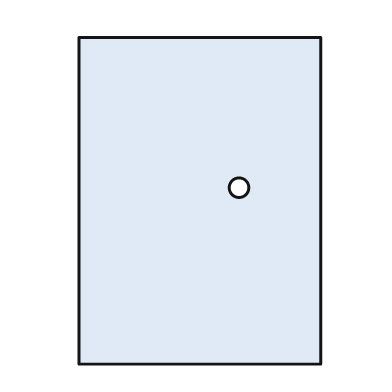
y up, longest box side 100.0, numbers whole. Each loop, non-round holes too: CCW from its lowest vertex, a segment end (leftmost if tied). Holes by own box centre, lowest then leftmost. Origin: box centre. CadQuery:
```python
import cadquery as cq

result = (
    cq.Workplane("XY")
    .moveTo(-37.0, -50.0)
    .lineTo(37.0, -50.0)
    .lineTo(37.0, 50.0)
    .lineTo(-37.0, 50.0)
    .close()
    .moveTo(12.0, 4.0)
    .circle(3.0)
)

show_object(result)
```